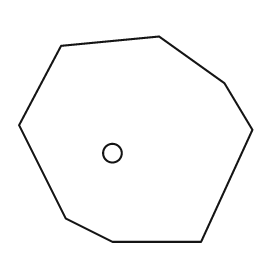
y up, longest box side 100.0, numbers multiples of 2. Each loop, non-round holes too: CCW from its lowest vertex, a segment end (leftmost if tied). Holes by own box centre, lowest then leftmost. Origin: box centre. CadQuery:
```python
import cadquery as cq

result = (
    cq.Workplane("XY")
    .moveTo(-10.0, -44.0)
    .lineTo(28.0, -44.0)
    .lineTo(50.0, 4.0)
    .lineTo(38.0, 24.0)
    .lineTo(10.0, 44.0)
    .lineTo(-32.0, 40.0)
    .lineTo(-50.0, 6.0)
    .lineTo(-30.0, -34.0)
    .close()
    .moveTo(-10.0, -6.0)
    .circle(4.0)
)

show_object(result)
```